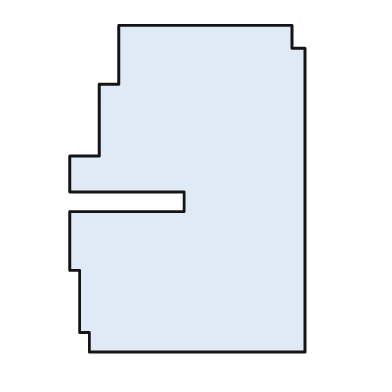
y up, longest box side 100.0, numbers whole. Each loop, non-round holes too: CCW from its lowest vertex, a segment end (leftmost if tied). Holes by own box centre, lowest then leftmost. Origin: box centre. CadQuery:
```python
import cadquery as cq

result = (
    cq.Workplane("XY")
    .moveTo(-30.0, -50.0)
    .lineTo(36.0, -50.0)
    .lineTo(36.0, 43.0)
    .lineTo(32.0, 43.0)
    .lineTo(32.0, 50.0)
    .lineTo(-21.0, 50.0)
    .lineTo(-21.0, 32.0)
    .lineTo(-27.0, 32.0)
    .lineTo(-27.0, 10.0)
    .lineTo(-36.0, 10.0)
    .lineTo(-36.0, -1.0)
    .lineTo(-1.0, -1.0)
    .lineTo(-1.0, -7.0)
    .lineTo(-36.0, -7.0)
    .lineTo(-36.0, -25.0)
    .lineTo(-33.0, -25.0)
    .lineTo(-33.0, -44.0)
    .lineTo(-30.0, -44.0)
    .close()
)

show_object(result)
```